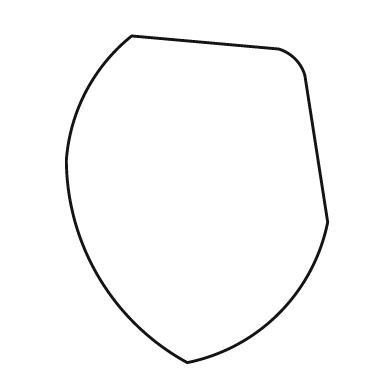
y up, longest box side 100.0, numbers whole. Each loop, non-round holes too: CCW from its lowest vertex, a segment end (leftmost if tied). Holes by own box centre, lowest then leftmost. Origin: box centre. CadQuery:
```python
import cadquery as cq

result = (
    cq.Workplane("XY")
    .moveTo(-3.0, -50.0)
    .threePointArc((25.0, -35.0), (40.0, -7.0))
    .lineTo(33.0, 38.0)
    .threePointArc((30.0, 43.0), (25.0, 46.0))
    .lineTo(-20.0, 50.0)
    .threePointArc((-34.0, 33.0), (-40.0, 12.0))
    .threePointArc((-30.0, -24.0), (-3.0, -50.0))
    .close()
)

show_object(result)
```